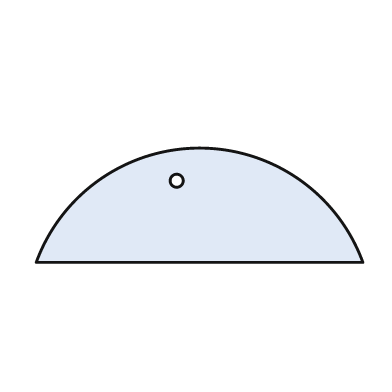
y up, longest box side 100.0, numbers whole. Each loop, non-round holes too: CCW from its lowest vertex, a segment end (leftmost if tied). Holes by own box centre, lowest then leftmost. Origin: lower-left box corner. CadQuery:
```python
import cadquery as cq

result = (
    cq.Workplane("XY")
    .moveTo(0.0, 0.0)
    .lineTo(100.0, 0.0)
    .threePointArc((50.0, 35.0), (0.0, 0.0))
    .close()
    .moveTo(43.0, 25.0)
    .circle(2.0)
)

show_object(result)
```